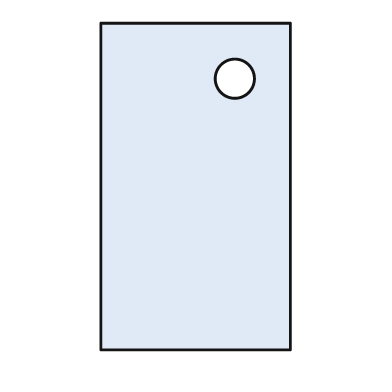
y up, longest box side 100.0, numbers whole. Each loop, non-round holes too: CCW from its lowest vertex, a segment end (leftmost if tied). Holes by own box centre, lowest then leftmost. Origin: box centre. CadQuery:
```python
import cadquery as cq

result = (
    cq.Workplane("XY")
    .moveTo(-29.0, -50.0)
    .lineTo(29.0, -50.0)
    .lineTo(29.0, 50.0)
    .lineTo(-29.0, 50.0)
    .close()
    .moveTo(12.0, 33.0)
    .circle(6.0)
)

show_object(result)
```